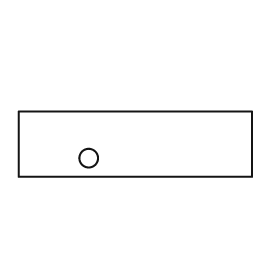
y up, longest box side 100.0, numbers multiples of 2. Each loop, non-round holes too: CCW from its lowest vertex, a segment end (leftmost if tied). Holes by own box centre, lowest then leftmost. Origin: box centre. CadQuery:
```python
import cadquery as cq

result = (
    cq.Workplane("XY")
    .moveTo(-50.0, -14.0)
    .lineTo(50.0, -14.0)
    .lineTo(50.0, 14.0)
    .lineTo(-50.0, 14.0)
    .close()
    .moveTo(-20.0, -6.0)
    .circle(4.0)
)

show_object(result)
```